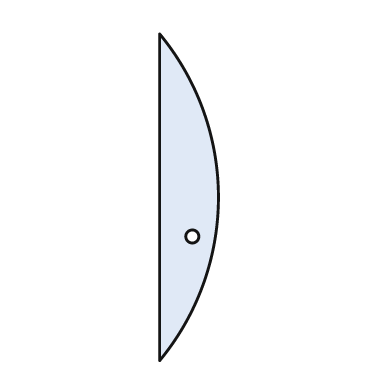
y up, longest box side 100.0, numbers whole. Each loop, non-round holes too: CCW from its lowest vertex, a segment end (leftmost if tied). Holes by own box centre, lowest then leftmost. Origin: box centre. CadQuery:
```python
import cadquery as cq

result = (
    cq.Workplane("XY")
    .moveTo(-9.0, -50.0)
    .threePointArc((9.0, 0.0), (-9.0, 50.0))
    .close()
    .moveTo(1.0, -12.0)
    .circle(2.0)
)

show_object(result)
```